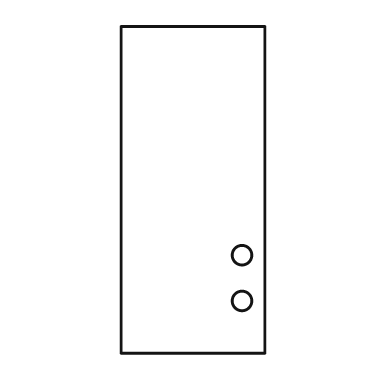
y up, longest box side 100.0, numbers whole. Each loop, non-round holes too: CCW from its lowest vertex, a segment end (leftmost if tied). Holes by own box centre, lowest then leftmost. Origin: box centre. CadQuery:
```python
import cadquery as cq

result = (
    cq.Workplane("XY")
    .moveTo(-22.0, -50.0)
    .lineTo(22.0, -50.0)
    .lineTo(22.0, 50.0)
    .lineTo(-22.0, 50.0)
    .close()
    .moveTo(15.0, -34.0)
    .circle(3.0)
    .moveTo(15.0, -20.0)
    .circle(3.0)
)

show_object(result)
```